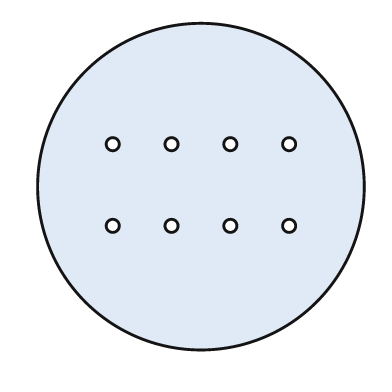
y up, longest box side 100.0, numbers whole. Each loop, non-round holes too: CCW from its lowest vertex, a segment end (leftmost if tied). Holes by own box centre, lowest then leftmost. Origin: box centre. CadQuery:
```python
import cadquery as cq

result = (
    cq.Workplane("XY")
    .moveTo(0.0, 0.0)
    .circle(50.0)
    .moveTo(-27.0, -12.0)
    .circle(2.0)
    .moveTo(-9.0, -12.0)
    .circle(2.0)
    .moveTo(9.0, -12.0)
    .circle(2.0)
    .moveTo(27.0, -12.0)
    .circle(2.0)
    .moveTo(-27.0, 13.0)
    .circle(2.0)
    .moveTo(-9.0, 13.0)
    .circle(2.0)
    .moveTo(9.0, 13.0)
    .circle(2.0)
    .moveTo(27.0, 13.0)
    .circle(2.0)
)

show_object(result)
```